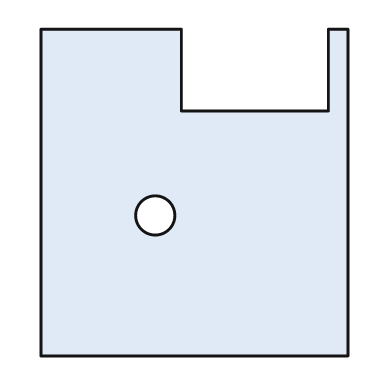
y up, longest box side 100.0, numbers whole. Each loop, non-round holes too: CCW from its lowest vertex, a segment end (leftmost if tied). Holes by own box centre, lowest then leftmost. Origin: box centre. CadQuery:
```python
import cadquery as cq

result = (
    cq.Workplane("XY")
    .moveTo(-47.0, -50.0)
    .lineTo(47.0, -50.0)
    .lineTo(47.0, 50.0)
    .lineTo(41.0, 50.0)
    .lineTo(41.0, 25.0)
    .lineTo(-4.0, 25.0)
    .lineTo(-4.0, 50.0)
    .lineTo(-47.0, 50.0)
    .close()
    .moveTo(-12.0, -7.0)
    .circle(6.0)
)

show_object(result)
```